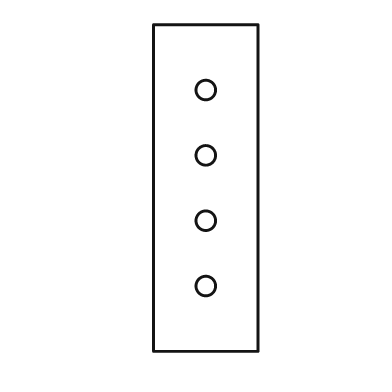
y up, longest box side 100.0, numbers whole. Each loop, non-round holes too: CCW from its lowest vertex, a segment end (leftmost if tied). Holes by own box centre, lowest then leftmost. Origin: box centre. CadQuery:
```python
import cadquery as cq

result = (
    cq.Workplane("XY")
    .moveTo(-16.0, -50.0)
    .lineTo(16.0, -50.0)
    .lineTo(16.0, 50.0)
    .lineTo(-16.0, 50.0)
    .close()
    .moveTo(0.0, -30.0)
    .circle(3.0)
    .moveTo(0.0, -10.0)
    .circle(3.0)
    .moveTo(0.0, 10.0)
    .circle(3.0)
    .moveTo(0.0, 30.0)
    .circle(3.0)
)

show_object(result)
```